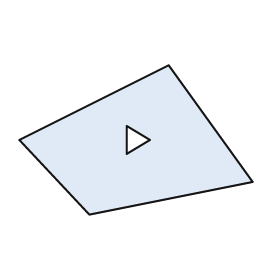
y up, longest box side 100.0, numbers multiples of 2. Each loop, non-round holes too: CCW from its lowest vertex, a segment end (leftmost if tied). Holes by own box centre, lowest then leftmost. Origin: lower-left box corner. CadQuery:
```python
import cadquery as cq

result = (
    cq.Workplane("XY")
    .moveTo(30.0, 0.0)
    .lineTo(100.0, 14.0)
    .lineTo(64.0, 64.0)
    .lineTo(0.0, 32.0)
    .close()
    .moveTo(46.0, 26.0)
    .lineTo(56.0, 32.0)
    .lineTo(46.0, 38.0)
    .close()
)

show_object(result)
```